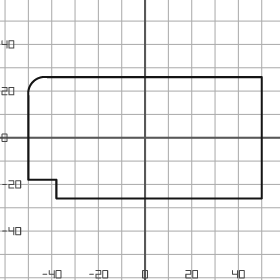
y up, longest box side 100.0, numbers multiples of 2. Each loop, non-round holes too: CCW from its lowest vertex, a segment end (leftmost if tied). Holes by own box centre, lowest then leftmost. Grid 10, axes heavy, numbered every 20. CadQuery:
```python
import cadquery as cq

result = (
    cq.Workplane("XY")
    .moveTo(-38.0, -26.0)
    .lineTo(50.0, -26.0)
    .lineTo(50.0, 26.0)
    .lineTo(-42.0, 26.0)
    .threePointArc((-48.0, 24.0), (-50.0, 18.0))
    .lineTo(-50.0, -18.0)
    .lineTo(-38.0, -18.0)
    .close()
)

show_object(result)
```